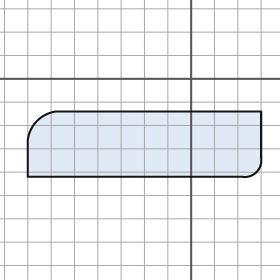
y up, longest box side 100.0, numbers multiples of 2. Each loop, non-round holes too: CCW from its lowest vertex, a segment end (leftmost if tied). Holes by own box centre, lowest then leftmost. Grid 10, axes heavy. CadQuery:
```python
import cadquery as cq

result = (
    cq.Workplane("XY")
    .moveTo(-70.0, -42.0)
    .lineTo(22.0, -42.0)
    .threePointArc((28.0, -40.0), (30.0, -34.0))
    .lineTo(30.0, -14.0)
    .lineTo(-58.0, -14.0)
    .threePointArc((-66.0, -18.0), (-70.0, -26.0))
    .close()
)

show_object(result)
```